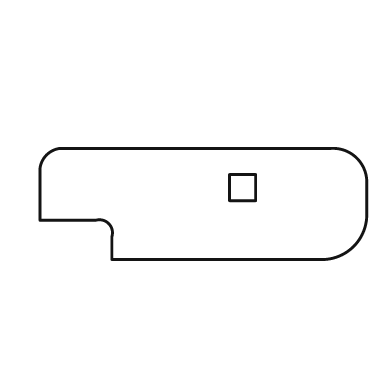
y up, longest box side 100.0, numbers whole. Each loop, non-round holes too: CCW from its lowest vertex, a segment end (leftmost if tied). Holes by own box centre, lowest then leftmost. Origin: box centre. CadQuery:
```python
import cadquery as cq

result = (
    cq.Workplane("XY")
    .moveTo(-28.0, -17.0)
    .lineTo(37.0, -17.0)
    .threePointArc((46.0, -13.0), (50.0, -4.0))
    .lineTo(50.0, 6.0)
    .threePointArc((47.0, 14.0), (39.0, 17.0))
    .lineTo(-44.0, 17.0)
    .threePointArc((-48.0, 15.0), (-50.0, 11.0))
    .lineTo(-50.0, -5.0)
    .lineTo(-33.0, -5.0)
    .threePointArc((-29.0, -6.0), (-28.0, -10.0))
    .close()
    .moveTo(8.0, 1.0)
    .lineTo(16.0, 1.0)
    .lineTo(16.0, 9.0)
    .lineTo(8.0, 9.0)
    .close()
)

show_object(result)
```